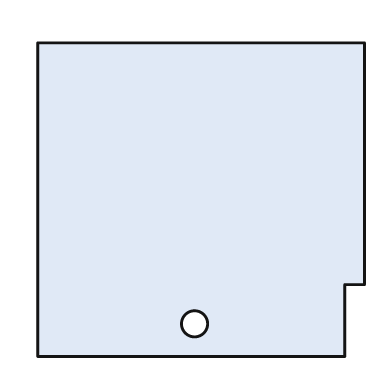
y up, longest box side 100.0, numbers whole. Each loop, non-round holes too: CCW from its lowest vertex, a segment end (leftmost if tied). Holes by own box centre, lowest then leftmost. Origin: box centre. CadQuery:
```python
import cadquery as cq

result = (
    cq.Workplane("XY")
    .moveTo(-50.0, -48.0)
    .lineTo(44.0, -48.0)
    .lineTo(44.0, -26.0)
    .lineTo(50.0, -26.0)
    .lineTo(50.0, 48.0)
    .lineTo(-50.0, 48.0)
    .close()
    .moveTo(-2.0, -38.0)
    .circle(4.0)
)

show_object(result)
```